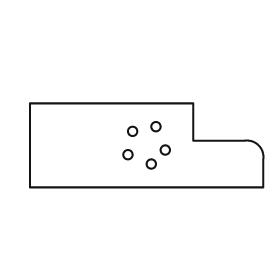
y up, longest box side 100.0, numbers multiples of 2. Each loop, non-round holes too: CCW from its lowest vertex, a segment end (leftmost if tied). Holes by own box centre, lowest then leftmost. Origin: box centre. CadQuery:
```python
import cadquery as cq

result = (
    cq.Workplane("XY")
    .moveTo(-50.0, -18.0)
    .lineTo(50.0, -18.0)
    .lineTo(50.0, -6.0)
    .threePointArc((48.0, 0.0), (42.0, 2.0))
    .lineTo(20.0, 2.0)
    .lineTo(20.0, 18.0)
    .lineTo(-50.0, 18.0)
    .close()
    .moveTo(2.0, -8.0)
    .circle(2.0)
    .moveTo(-8.0, -4.0)
    .circle(2.0)
    .moveTo(8.0, -2.0)
    .circle(2.0)
    .moveTo(-6.0, 6.0)
    .circle(2.0)
    .moveTo(4.0, 8.0)
    .circle(2.0)
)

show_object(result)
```